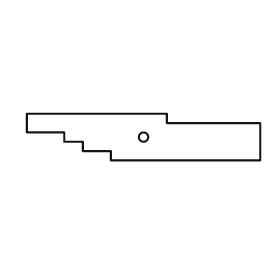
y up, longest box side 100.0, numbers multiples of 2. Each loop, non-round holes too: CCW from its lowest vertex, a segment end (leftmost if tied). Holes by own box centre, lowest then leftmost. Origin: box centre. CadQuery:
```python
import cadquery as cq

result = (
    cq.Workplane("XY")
    .moveTo(-14.0, -10.0)
    .lineTo(50.0, -10.0)
    .lineTo(50.0, 6.0)
    .lineTo(10.0, 6.0)
    .lineTo(10.0, 10.0)
    .lineTo(-50.0, 10.0)
    .lineTo(-50.0, 2.0)
    .lineTo(-34.0, 2.0)
    .lineTo(-34.0, -2.0)
    .lineTo(-26.0, -2.0)
    .lineTo(-26.0, -6.0)
    .lineTo(-14.0, -6.0)
    .close()
    .moveTo(0.0, 0.0)
    .circle(2.0)
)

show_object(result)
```